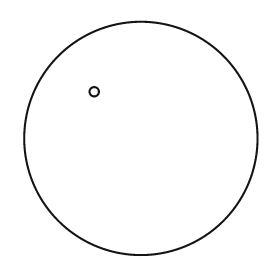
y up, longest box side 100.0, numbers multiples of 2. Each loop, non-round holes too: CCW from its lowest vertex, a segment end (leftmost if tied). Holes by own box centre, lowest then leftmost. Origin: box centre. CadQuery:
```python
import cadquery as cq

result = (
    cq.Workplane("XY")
    .moveTo(0.0, 0.0)
    .circle(50.0)
    .moveTo(-20.0, 20.0)
    .circle(2.0)
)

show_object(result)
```